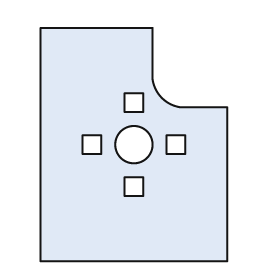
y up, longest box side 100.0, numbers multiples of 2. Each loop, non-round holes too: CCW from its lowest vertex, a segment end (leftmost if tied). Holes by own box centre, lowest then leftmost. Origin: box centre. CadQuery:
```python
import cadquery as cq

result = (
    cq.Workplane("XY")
    .moveTo(-40.0, -50.0)
    .lineTo(40.0, -50.0)
    .lineTo(40.0, 16.0)
    .lineTo(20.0, 16.0)
    .threePointArc((12.0, 20.0), (8.0, 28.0))
    .lineTo(8.0, 50.0)
    .lineTo(-40.0, 50.0)
    .close()
    .moveTo(-4.0, -22.0)
    .lineTo(4.0, -22.0)
    .lineTo(4.0, -14.0)
    .lineTo(-4.0, -14.0)
    .close()
    .moveTo(-22.0, -4.0)
    .lineTo(-14.0, -4.0)
    .lineTo(-14.0, 4.0)
    .lineTo(-22.0, 4.0)
    .close()
    .moveTo(0.0, 0.0)
    .circle(8.0)
    .moveTo(14.0, -4.0)
    .lineTo(22.0, -4.0)
    .lineTo(22.0, 4.0)
    .lineTo(14.0, 4.0)
    .close()
    .moveTo(-4.0, 14.0)
    .lineTo(4.0, 14.0)
    .lineTo(4.0, 22.0)
    .lineTo(-4.0, 22.0)
    .close()
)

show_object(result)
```